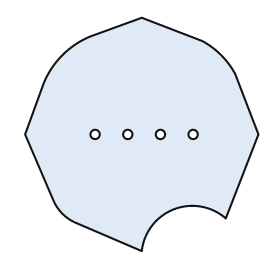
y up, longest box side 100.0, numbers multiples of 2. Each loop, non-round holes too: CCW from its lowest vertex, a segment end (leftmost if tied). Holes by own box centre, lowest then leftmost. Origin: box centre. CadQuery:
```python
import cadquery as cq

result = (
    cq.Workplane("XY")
    .moveTo(0.0, -50.0)
    .threePointArc((14.0, -32.0), (36.0, -36.0))
    .lineTo(50.0, 0.0)
    .lineTo(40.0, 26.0)
    .threePointArc((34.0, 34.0), (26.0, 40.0))
    .lineTo(0.0, 50.0)
    .lineTo(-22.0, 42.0)
    .threePointArc((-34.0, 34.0), (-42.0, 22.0))
    .lineTo(-50.0, 0.0)
    .lineTo(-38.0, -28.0)
    .threePointArc((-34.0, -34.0), (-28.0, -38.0))
    .close()
    .moveTo(-20.0, 0.0)
    .circle(2.0)
    .moveTo(-6.0, 0.0)
    .circle(2.0)
    .moveTo(8.0, 0.0)
    .circle(2.0)
    .moveTo(22.0, 0.0)
    .circle(2.0)
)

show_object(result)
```